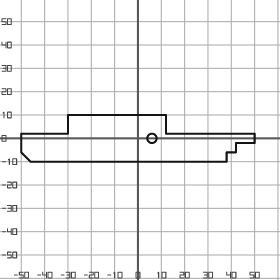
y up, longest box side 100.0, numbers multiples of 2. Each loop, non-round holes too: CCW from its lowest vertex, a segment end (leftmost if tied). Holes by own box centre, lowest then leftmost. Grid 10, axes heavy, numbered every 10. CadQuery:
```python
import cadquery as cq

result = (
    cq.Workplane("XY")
    .moveTo(-46.0, -10.0)
    .lineTo(38.0, -10.0)
    .lineTo(38.0, -6.0)
    .lineTo(42.0, -6.0)
    .lineTo(42.0, -2.0)
    .lineTo(50.0, -2.0)
    .lineTo(50.0, 2.0)
    .lineTo(12.0, 2.0)
    .lineTo(12.0, 10.0)
    .lineTo(-30.0, 10.0)
    .lineTo(-30.0, 2.0)
    .lineTo(-50.0, 2.0)
    .lineTo(-50.0, -6.0)
    .close()
    .moveTo(6.0, 0.0)
    .circle(2.0)
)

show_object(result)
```